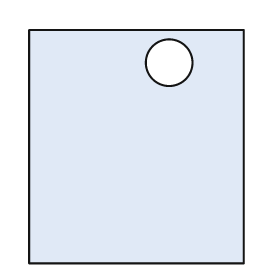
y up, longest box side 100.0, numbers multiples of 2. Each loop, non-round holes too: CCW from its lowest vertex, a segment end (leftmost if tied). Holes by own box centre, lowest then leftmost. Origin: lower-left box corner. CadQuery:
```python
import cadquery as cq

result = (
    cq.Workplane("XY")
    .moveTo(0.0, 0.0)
    .lineTo(92.0, 0.0)
    .lineTo(92.0, 100.0)
    .lineTo(0.0, 100.0)
    .close()
    .moveTo(60.0, 86.0)
    .circle(10.0)
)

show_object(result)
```